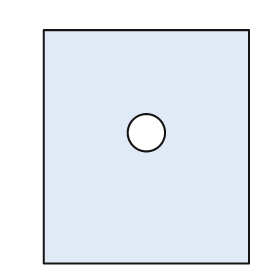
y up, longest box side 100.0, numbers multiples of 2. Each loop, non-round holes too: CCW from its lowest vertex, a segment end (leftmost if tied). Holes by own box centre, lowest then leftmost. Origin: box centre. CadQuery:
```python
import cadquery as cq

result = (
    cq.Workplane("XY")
    .moveTo(-44.0, -50.0)
    .lineTo(44.0, -50.0)
    .lineTo(44.0, 50.0)
    .lineTo(-44.0, 50.0)
    .close()
    .moveTo(0.0, 6.0)
    .circle(8.0)
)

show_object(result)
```